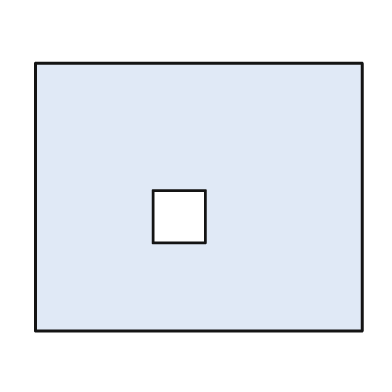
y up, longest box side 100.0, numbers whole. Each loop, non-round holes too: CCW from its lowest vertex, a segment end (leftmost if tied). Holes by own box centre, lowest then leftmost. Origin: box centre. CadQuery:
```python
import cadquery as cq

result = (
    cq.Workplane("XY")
    .moveTo(-50.0, -41.0)
    .lineTo(50.0, -41.0)
    .lineTo(50.0, 41.0)
    .lineTo(-50.0, 41.0)
    .close()
    .moveTo(-14.0, -14.0)
    .lineTo(2.0, -14.0)
    .lineTo(2.0, 2.0)
    .lineTo(-14.0, 2.0)
    .close()
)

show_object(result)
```